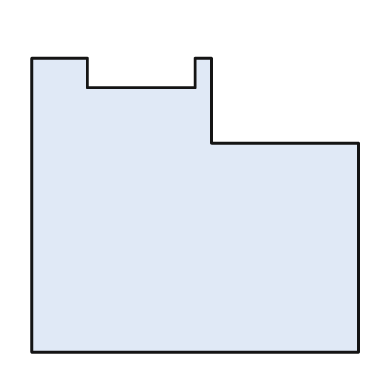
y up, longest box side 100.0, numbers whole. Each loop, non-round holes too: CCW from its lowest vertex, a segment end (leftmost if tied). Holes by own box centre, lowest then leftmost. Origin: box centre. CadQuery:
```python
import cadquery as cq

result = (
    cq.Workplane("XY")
    .moveTo(-50.0, -45.0)
    .lineTo(50.0, -45.0)
    .lineTo(50.0, 19.0)
    .lineTo(5.0, 19.0)
    .lineTo(5.0, 45.0)
    .lineTo(0.0, 45.0)
    .lineTo(0.0, 36.0)
    .lineTo(-33.0, 36.0)
    .lineTo(-33.0, 45.0)
    .lineTo(-50.0, 45.0)
    .close()
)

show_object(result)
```